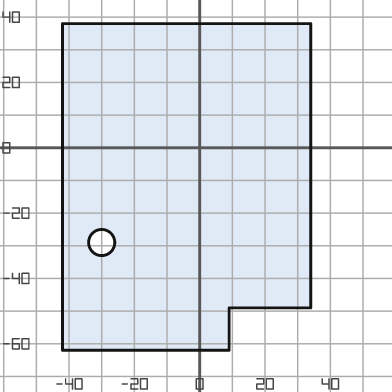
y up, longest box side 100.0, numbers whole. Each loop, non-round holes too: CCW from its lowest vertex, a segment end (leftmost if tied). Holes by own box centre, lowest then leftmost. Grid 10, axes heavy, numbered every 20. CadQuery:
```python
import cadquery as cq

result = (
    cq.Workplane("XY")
    .moveTo(-42.0, -62.0)
    .lineTo(9.0, -62.0)
    .lineTo(9.0, -49.0)
    .lineTo(34.0, -49.0)
    .lineTo(34.0, 38.0)
    .lineTo(-42.0, 38.0)
    .close()
    .moveTo(-30.0, -29.0)
    .circle(4.0)
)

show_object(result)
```